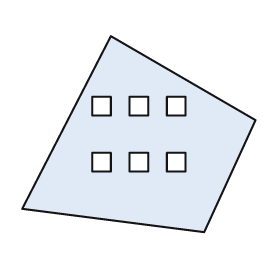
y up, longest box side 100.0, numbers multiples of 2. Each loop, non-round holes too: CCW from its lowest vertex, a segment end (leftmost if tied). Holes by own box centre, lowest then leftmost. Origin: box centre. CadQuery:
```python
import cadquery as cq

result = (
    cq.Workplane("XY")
    .moveTo(28.0, -42.0)
    .lineTo(50.0, 6.0)
    .lineTo(-12.0, 42.0)
    .lineTo(-50.0, -32.0)
    .close()
    .moveTo(-20.0, -16.0)
    .lineTo(-12.0, -16.0)
    .lineTo(-12.0, -8.0)
    .lineTo(-20.0, -8.0)
    .close()
    .moveTo(-4.0, -16.0)
    .lineTo(4.0, -16.0)
    .lineTo(4.0, -8.0)
    .lineTo(-4.0, -8.0)
    .close()
    .moveTo(12.0, -16.0)
    .lineTo(20.0, -16.0)
    .lineTo(20.0, -8.0)
    .lineTo(12.0, -8.0)
    .close()
    .moveTo(-20.0, 8.0)
    .lineTo(-12.0, 8.0)
    .lineTo(-12.0, 16.0)
    .lineTo(-20.0, 16.0)
    .close()
    .moveTo(-4.0, 8.0)
    .lineTo(4.0, 8.0)
    .lineTo(4.0, 16.0)
    .lineTo(-4.0, 16.0)
    .close()
    .moveTo(12.0, 8.0)
    .lineTo(20.0, 8.0)
    .lineTo(20.0, 16.0)
    .lineTo(12.0, 16.0)
    .close()
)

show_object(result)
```